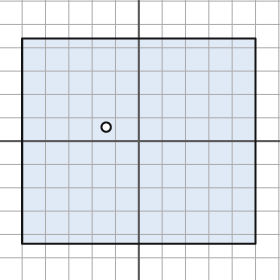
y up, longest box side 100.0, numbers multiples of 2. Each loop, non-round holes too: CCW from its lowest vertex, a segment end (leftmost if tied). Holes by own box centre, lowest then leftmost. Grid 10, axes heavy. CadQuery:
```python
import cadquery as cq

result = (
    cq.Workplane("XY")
    .moveTo(-50.0, -44.0)
    .lineTo(50.0, -44.0)
    .lineTo(50.0, 44.0)
    .lineTo(-50.0, 44.0)
    .close()
    .moveTo(-14.0, 6.0)
    .circle(2.0)
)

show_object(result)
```